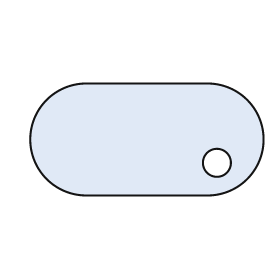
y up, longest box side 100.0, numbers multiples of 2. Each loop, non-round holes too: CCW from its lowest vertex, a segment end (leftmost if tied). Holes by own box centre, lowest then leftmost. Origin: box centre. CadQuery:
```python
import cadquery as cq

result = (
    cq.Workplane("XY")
    .moveTo(-26.0, -24.0)
    .lineTo(26.0, -24.0)
    .threePointArc((50.0, 0.0), (26.0, 24.0))
    .lineTo(-26.0, 24.0)
    .threePointArc((-50.0, 0.0), (-26.0, -24.0))
    .close()
    .moveTo(30.0, -10.0)
    .circle(6.0)
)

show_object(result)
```